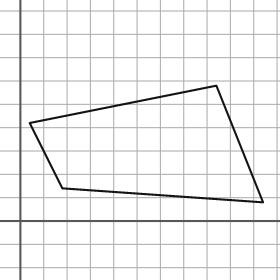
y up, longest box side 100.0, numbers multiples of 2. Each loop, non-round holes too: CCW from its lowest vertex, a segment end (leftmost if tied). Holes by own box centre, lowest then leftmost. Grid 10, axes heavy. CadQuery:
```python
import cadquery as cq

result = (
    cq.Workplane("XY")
    .moveTo(104.0, 8.0)
    .lineTo(84.0, 58.0)
    .lineTo(4.0, 42.0)
    .lineTo(18.0, 14.0)
    .close()
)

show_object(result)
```